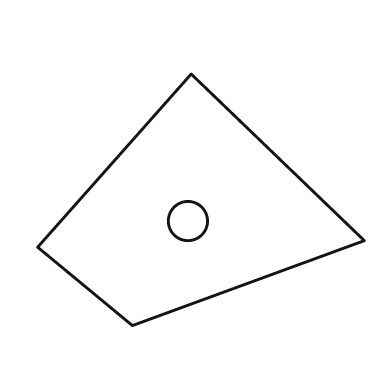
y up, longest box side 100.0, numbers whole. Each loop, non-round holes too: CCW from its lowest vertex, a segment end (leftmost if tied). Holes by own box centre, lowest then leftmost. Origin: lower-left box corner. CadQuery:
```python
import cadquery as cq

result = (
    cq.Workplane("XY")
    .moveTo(29.0, 0.0)
    .lineTo(100.0, 26.0)
    .lineTo(47.0, 77.0)
    .lineTo(0.0, 24.0)
    .close()
    .moveTo(46.0, 32.0)
    .circle(6.0)
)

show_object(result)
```